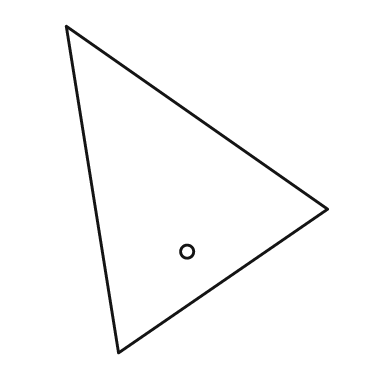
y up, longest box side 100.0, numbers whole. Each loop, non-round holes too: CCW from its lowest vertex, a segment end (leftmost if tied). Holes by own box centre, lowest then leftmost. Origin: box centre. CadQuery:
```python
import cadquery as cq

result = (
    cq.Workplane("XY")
    .moveTo(-24.0, -50.0)
    .lineTo(40.0, -6.0)
    .lineTo(-40.0, 50.0)
    .close()
    .moveTo(-3.0, -19.0)
    .circle(2.0)
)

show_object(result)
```